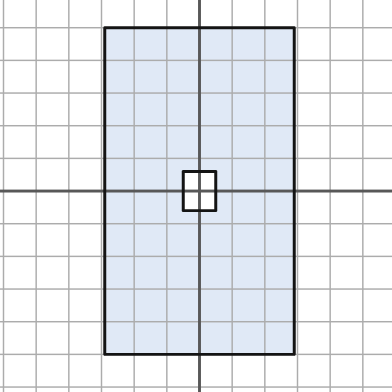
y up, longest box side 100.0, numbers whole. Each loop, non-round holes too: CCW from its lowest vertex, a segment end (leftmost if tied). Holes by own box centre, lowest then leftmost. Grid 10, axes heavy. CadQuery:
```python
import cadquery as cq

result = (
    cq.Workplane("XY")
    .moveTo(-29.0, -50.0)
    .lineTo(29.0, -50.0)
    .lineTo(29.0, 50.0)
    .lineTo(-29.0, 50.0)
    .close()
    .moveTo(-5.0, -6.0)
    .lineTo(5.0, -6.0)
    .lineTo(5.0, 6.0)
    .lineTo(-5.0, 6.0)
    .close()
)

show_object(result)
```